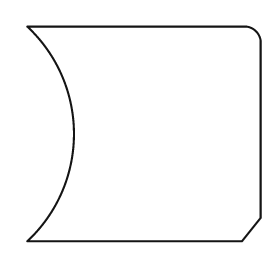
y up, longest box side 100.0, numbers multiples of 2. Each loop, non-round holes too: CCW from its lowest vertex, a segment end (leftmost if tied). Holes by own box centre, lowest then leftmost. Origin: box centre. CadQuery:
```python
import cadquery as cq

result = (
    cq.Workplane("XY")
    .moveTo(-50.0, -46.0)
    .lineTo(42.0, -46.0)
    .lineTo(50.0, -36.0)
    .lineTo(50.0, 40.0)
    .threePointArc((48.0, 44.0), (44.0, 46.0))
    .lineTo(-50.0, 46.0)
    .threePointArc((-30.0, 0.0), (-50.0, -46.0))
    .close()
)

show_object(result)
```